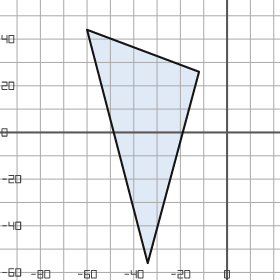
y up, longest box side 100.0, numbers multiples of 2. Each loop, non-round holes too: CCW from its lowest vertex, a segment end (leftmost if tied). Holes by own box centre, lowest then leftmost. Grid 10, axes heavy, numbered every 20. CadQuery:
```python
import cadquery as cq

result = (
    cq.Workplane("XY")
    .moveTo(-34.0, -56.0)
    .lineTo(-12.0, 26.0)
    .lineTo(-60.0, 44.0)
    .close()
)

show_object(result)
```